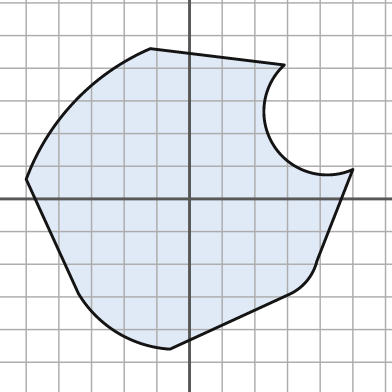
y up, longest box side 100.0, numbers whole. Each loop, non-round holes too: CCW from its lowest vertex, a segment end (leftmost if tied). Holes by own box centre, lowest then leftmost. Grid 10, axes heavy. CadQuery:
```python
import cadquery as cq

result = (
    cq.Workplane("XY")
    .moveTo(-6.0, -46.0)
    .lineTo(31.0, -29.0)
    .threePointArc((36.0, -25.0), (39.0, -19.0))
    .lineTo(50.0, 9.0)
    .threePointArc((26.0, 16.0), (29.0, 41.0))
    .lineTo(-12.0, 46.0)
    .threePointArc((-35.0, 30.0), (-50.0, 6.0))
    .lineTo(-34.0, -29.0)
    .threePointArc((-22.0, -41.0), (-6.0, -46.0))
    .close()
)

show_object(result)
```